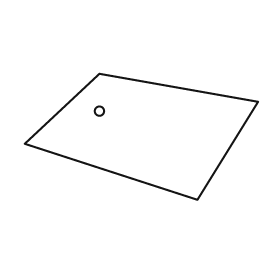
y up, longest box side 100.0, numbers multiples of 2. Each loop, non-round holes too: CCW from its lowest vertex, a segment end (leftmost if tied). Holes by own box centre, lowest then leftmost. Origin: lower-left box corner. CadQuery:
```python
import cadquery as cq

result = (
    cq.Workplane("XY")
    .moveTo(74.0, 0.0)
    .lineTo(100.0, 42.0)
    .lineTo(32.0, 54.0)
    .lineTo(0.0, 24.0)
    .close()
    .moveTo(32.0, 38.0)
    .circle(2.0)
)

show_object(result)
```